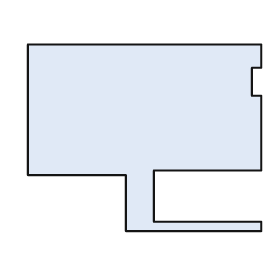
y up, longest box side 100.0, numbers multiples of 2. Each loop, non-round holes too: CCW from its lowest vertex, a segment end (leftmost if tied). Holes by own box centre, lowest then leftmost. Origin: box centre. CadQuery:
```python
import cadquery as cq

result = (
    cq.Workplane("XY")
    .moveTo(-8.0, -40.0)
    .lineTo(50.0, -40.0)
    .lineTo(50.0, -36.0)
    .lineTo(4.0, -36.0)
    .lineTo(4.0, -14.0)
    .lineTo(50.0, -14.0)
    .lineTo(50.0, 18.0)
    .lineTo(46.0, 18.0)
    .lineTo(46.0, 30.0)
    .lineTo(50.0, 30.0)
    .lineTo(50.0, 40.0)
    .lineTo(-50.0, 40.0)
    .lineTo(-50.0, -16.0)
    .lineTo(-8.0, -16.0)
    .close()
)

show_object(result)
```